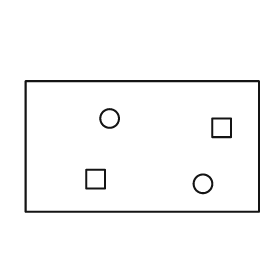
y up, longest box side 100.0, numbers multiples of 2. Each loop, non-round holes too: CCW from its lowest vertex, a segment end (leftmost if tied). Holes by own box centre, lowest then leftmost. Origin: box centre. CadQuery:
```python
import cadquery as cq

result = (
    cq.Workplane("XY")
    .moveTo(-50.0, -28.0)
    .lineTo(50.0, -28.0)
    .lineTo(50.0, 28.0)
    .lineTo(-50.0, 28.0)
    .close()
    .moveTo(26.0, -16.0)
    .circle(4.0)
    .moveTo(-24.0, -18.0)
    .lineTo(-16.0, -18.0)
    .lineTo(-16.0, -10.0)
    .lineTo(-24.0, -10.0)
    .close()
    .moveTo(30.0, 4.0)
    .lineTo(38.0, 4.0)
    .lineTo(38.0, 12.0)
    .lineTo(30.0, 12.0)
    .close()
    .moveTo(-14.0, 12.0)
    .circle(4.0)
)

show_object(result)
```